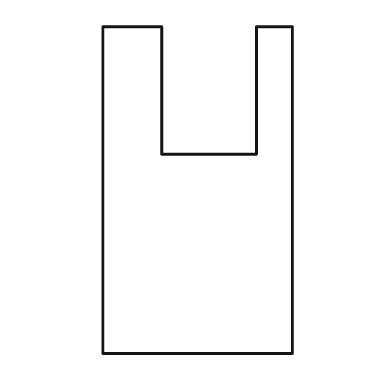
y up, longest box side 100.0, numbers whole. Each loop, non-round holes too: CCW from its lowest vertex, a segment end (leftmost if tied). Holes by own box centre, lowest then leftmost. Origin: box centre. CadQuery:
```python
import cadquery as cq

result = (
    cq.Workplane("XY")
    .moveTo(-29.0, -50.0)
    .lineTo(29.0, -50.0)
    .lineTo(29.0, 50.0)
    .lineTo(18.0, 50.0)
    .lineTo(18.0, 11.0)
    .lineTo(-11.0, 11.0)
    .lineTo(-11.0, 50.0)
    .lineTo(-29.0, 50.0)
    .close()
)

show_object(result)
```